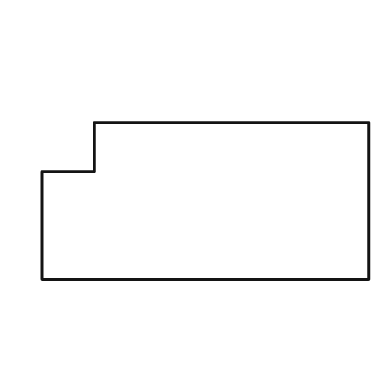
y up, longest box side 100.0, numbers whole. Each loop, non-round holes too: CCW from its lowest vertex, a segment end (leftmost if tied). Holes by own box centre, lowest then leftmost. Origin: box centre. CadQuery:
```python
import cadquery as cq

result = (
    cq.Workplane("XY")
    .moveTo(-50.0, -24.0)
    .lineTo(50.0, -24.0)
    .lineTo(50.0, 24.0)
    .lineTo(-34.0, 24.0)
    .lineTo(-34.0, 9.0)
    .lineTo(-50.0, 9.0)
    .close()
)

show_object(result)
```